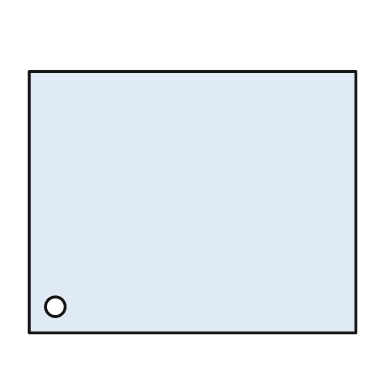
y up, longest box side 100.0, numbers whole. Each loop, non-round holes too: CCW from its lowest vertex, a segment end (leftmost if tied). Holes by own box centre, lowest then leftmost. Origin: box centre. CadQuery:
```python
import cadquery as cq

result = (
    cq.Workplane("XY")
    .moveTo(-50.0, -40.0)
    .lineTo(50.0, -40.0)
    .lineTo(50.0, 40.0)
    .lineTo(-50.0, 40.0)
    .close()
    .moveTo(-42.0, -32.0)
    .circle(3.0)
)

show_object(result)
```